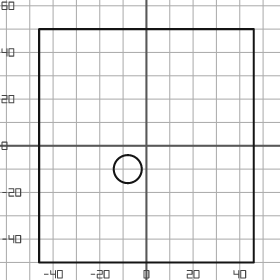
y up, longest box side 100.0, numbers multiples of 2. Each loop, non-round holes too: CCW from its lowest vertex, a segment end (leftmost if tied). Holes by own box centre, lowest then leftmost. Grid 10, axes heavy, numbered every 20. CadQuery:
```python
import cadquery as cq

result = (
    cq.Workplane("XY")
    .moveTo(-46.0, -50.0)
    .lineTo(46.0, -50.0)
    .lineTo(46.0, 50.0)
    .lineTo(-46.0, 50.0)
    .close()
    .moveTo(-8.0, -10.0)
    .circle(6.0)
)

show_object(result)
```